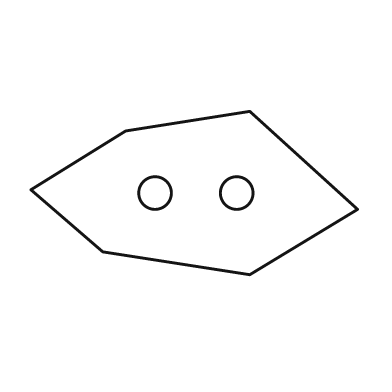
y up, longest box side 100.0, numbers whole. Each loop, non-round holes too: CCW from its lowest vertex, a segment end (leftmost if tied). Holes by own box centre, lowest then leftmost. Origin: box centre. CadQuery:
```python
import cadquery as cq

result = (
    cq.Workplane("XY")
    .moveTo(17.0, -25.0)
    .lineTo(50.0, -5.0)
    .lineTo(17.0, 25.0)
    .lineTo(-21.0, 19.0)
    .lineTo(-50.0, 1.0)
    .lineTo(-28.0, -18.0)
    .close()
    .moveTo(-12.0, 0.0)
    .circle(5.0)
    .moveTo(13.0, 0.0)
    .circle(5.0)
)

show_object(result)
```